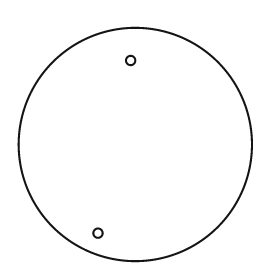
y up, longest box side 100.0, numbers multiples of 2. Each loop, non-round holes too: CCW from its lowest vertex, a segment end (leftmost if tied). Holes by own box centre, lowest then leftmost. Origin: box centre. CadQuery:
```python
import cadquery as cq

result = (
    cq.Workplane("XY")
    .moveTo(0.0, 0.0)
    .circle(50.0)
    .moveTo(-16.0, -38.0)
    .circle(2.0)
    .moveTo(-2.0, 36.0)
    .circle(2.0)
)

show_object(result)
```